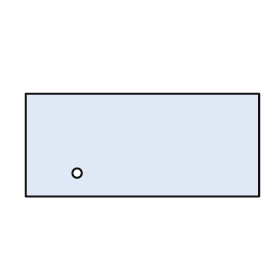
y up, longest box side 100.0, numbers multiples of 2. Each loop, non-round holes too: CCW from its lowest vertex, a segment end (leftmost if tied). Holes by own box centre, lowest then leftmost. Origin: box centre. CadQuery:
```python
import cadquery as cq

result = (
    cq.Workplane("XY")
    .moveTo(-50.0, -22.0)
    .lineTo(50.0, -22.0)
    .lineTo(50.0, 22.0)
    .lineTo(-50.0, 22.0)
    .close()
    .moveTo(-28.0, -12.0)
    .circle(2.0)
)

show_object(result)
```